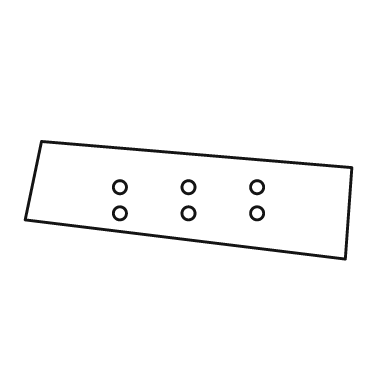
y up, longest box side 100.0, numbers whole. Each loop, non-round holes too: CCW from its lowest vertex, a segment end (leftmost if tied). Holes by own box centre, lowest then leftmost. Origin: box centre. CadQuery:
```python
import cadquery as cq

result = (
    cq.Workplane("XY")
    .moveTo(48.0, -18.0)
    .lineTo(50.0, 10.0)
    .lineTo(-45.0, 18.0)
    .lineTo(-50.0, -6.0)
    .close()
    .moveTo(-21.0, -4.0)
    .circle(2.0)
    .moveTo(0.0, -4.0)
    .circle(2.0)
    .moveTo(21.0, -4.0)
    .circle(2.0)
    .moveTo(-21.0, 4.0)
    .circle(2.0)
    .moveTo(0.0, 4.0)
    .circle(2.0)
    .moveTo(21.0, 4.0)
    .circle(2.0)
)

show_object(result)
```